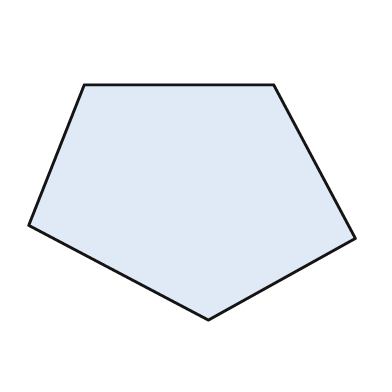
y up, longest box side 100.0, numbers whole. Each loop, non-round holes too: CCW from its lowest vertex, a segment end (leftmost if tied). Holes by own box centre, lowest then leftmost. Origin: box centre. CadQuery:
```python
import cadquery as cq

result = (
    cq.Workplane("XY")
    .moveTo(5.0, -36.0)
    .lineTo(50.0, -11.0)
    .lineTo(25.0, 36.0)
    .lineTo(-33.0, 36.0)
    .lineTo(-50.0, -7.0)
    .close()
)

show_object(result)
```